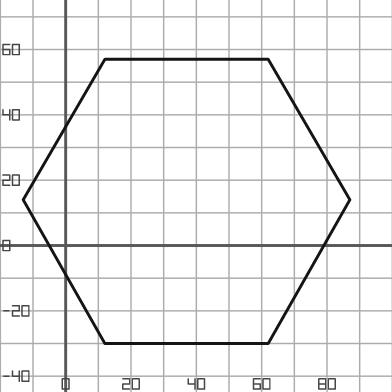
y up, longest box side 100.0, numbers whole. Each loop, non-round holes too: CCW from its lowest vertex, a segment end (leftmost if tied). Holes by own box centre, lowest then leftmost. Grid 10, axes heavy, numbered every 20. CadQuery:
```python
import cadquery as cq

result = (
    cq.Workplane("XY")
    .moveTo(12.0, -30.0)
    .lineTo(62.0, -30.0)
    .lineTo(87.0, 14.0)
    .lineTo(62.0, 57.0)
    .lineTo(12.0, 57.0)
    .lineTo(-13.0, 14.0)
    .close()
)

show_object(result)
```